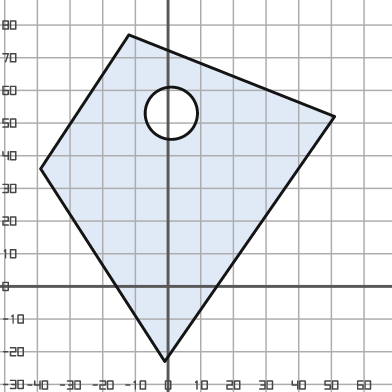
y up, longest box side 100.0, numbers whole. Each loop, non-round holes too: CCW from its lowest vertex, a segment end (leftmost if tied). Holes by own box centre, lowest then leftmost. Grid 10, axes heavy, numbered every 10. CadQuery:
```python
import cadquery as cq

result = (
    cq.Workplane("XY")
    .moveTo(-1.0, -23.0)
    .lineTo(51.0, 52.0)
    .lineTo(-12.0, 77.0)
    .lineTo(-39.0, 36.0)
    .close()
    .moveTo(1.0, 53.0)
    .circle(8.0)
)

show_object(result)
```